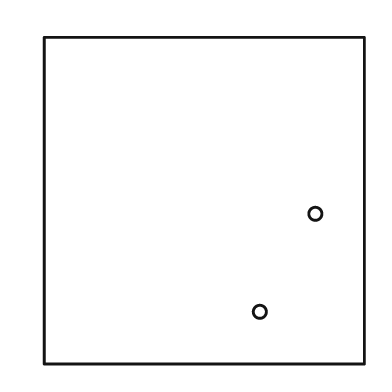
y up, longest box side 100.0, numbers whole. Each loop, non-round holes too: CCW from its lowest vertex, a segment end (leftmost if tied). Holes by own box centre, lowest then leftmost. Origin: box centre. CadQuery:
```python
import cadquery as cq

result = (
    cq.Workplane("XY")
    .moveTo(-49.0, -50.0)
    .lineTo(49.0, -50.0)
    .lineTo(49.0, 50.0)
    .lineTo(-49.0, 50.0)
    .close()
    .moveTo(17.0, -34.0)
    .circle(2.0)
    .moveTo(34.0, -4.0)
    .circle(2.0)
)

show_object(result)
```